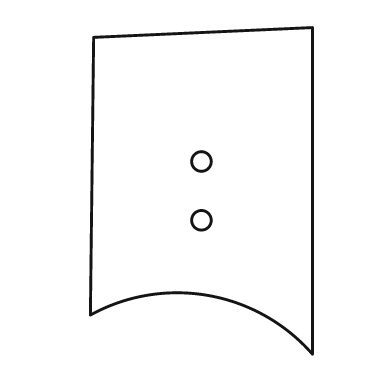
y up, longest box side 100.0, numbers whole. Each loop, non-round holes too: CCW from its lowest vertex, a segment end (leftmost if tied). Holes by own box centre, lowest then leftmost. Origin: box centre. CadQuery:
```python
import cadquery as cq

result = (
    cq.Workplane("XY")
    .moveTo(34.0, -50.0)
    .lineTo(34.0, 50.0)
    .lineTo(-33.0, 47.0)
    .lineTo(-34.0, -38.0)
    .threePointArc((2.0, -32.0), (34.0, -50.0))
    .close()
    .moveTo(0.0, -9.0)
    .circle(3.0)
    .moveTo(0.0, 9.0)
    .circle(3.0)
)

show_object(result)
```